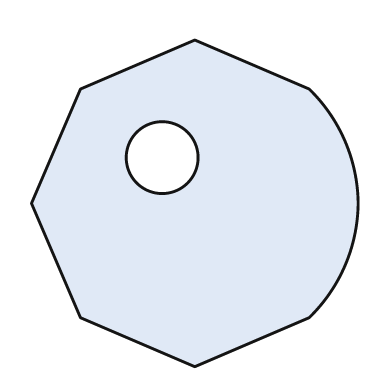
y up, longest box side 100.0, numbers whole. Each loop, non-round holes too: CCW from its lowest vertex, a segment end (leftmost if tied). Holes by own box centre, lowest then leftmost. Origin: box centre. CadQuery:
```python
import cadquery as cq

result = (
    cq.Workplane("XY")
    .moveTo(0.0, -50.0)
    .lineTo(35.0, -35.0)
    .threePointArc((46.0, -19.0), (50.0, 0.0))
    .threePointArc((46.0, 19.0), (35.0, 35.0))
    .lineTo(0.0, 50.0)
    .lineTo(-35.0, 35.0)
    .lineTo(-50.0, 0.0)
    .lineTo(-35.0, -35.0)
    .close()
    .moveTo(-10.0, 14.0)
    .circle(11.0)
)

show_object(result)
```